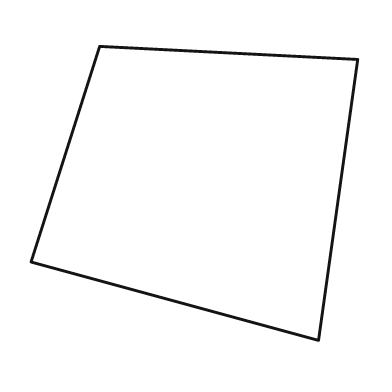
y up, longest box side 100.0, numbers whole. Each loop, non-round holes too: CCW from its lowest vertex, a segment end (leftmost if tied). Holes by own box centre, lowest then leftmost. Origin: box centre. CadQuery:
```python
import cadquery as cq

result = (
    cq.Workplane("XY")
    .moveTo(38.0, -45.0)
    .lineTo(50.0, 41.0)
    .lineTo(-29.0, 45.0)
    .lineTo(-50.0, -21.0)
    .close()
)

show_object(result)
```